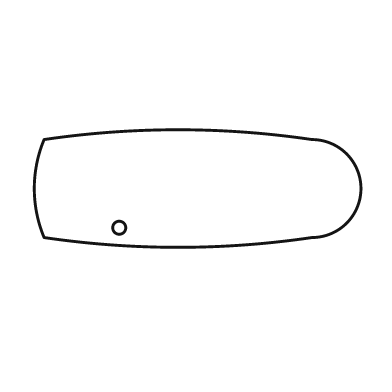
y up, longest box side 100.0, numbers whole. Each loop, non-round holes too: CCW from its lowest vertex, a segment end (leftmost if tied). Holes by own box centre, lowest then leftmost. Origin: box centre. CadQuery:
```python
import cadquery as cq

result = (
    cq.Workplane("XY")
    .moveTo(-47.0, -15.0)
    .threePointArc((-6.0, -18.0), (35.0, -15.0))
    .threePointArc((50.0, 0.0), (35.0, 15.0))
    .threePointArc((-6.0, 18.0), (-47.0, 15.0))
    .threePointArc((-50.0, 0.0), (-47.0, -15.0))
    .close()
    .moveTo(-24.0, -12.0)
    .circle(2.0)
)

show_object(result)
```